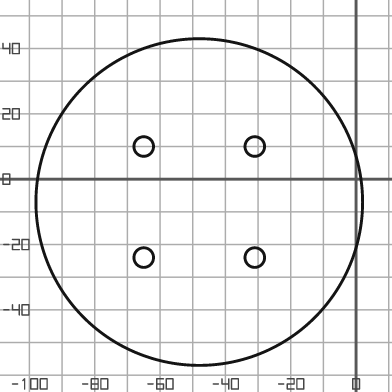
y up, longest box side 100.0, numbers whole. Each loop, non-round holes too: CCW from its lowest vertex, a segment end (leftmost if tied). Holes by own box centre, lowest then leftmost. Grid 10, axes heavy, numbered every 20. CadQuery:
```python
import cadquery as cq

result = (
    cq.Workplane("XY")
    .moveTo(-48.0, -7.0)
    .circle(50.0)
    .moveTo(-65.0, -24.0)
    .circle(3.0)
    .moveTo(-31.0, -24.0)
    .circle(3.0)
    .moveTo(-65.0, 10.0)
    .circle(3.0)
    .moveTo(-31.0, 10.0)
    .circle(3.0)
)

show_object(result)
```